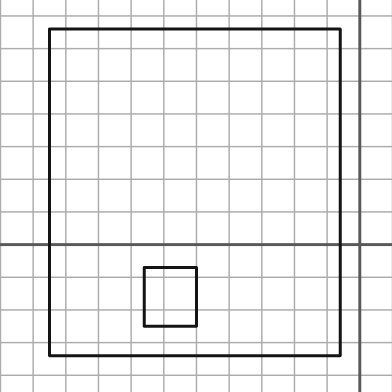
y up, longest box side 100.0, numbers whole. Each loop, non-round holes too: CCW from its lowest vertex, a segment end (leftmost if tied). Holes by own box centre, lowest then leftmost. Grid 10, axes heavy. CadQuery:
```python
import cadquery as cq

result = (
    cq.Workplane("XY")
    .moveTo(-95.0, -34.0)
    .lineTo(-6.0, -34.0)
    .lineTo(-6.0, 66.0)
    .lineTo(-95.0, 66.0)
    .close()
    .moveTo(-66.0, -25.0)
    .lineTo(-50.0, -25.0)
    .lineTo(-50.0, -7.0)
    .lineTo(-66.0, -7.0)
    .close()
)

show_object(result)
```